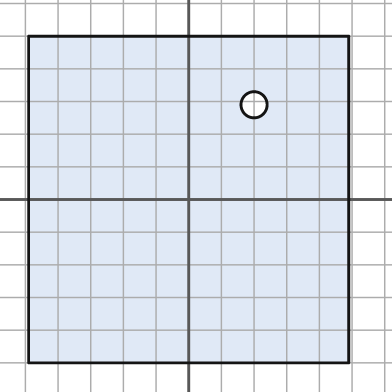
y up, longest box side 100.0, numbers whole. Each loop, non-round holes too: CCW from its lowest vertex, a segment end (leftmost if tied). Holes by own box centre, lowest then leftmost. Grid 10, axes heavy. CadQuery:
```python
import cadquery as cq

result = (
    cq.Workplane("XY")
    .moveTo(-49.0, -50.0)
    .lineTo(49.0, -50.0)
    .lineTo(49.0, 50.0)
    .lineTo(-49.0, 50.0)
    .close()
    .moveTo(20.0, 29.0)
    .circle(4.0)
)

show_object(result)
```